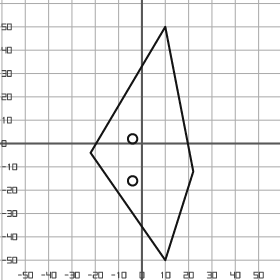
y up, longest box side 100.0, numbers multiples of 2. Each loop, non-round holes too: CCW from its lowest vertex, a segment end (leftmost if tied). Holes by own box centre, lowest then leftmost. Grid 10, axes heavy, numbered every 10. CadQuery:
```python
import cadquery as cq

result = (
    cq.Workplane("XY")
    .moveTo(10.0, -50.0)
    .lineTo(22.0, -12.0)
    .lineTo(10.0, 50.0)
    .lineTo(-22.0, -4.0)
    .close()
    .moveTo(-4.0, -16.0)
    .circle(2.0)
    .moveTo(-4.0, 2.0)
    .circle(2.0)
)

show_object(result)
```